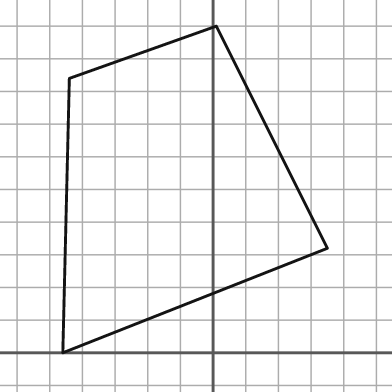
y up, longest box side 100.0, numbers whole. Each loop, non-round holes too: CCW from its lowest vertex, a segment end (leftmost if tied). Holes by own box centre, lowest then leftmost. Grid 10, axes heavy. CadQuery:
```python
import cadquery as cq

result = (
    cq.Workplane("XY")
    .moveTo(-46.0, 0.0)
    .lineTo(35.0, 32.0)
    .lineTo(1.0, 100.0)
    .lineTo(-44.0, 84.0)
    .close()
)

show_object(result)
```